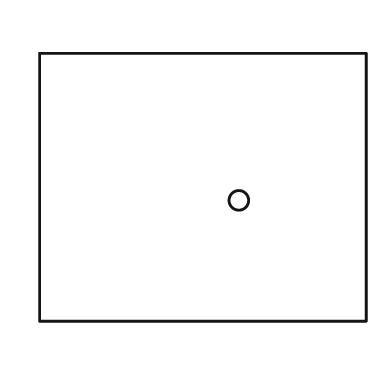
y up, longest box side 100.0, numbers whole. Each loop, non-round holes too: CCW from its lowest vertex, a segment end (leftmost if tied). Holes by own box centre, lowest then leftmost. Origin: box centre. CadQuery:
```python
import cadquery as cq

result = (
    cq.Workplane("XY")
    .moveTo(-50.0, -41.0)
    .lineTo(50.0, -41.0)
    .lineTo(50.0, 41.0)
    .lineTo(-50.0, 41.0)
    .close()
    .moveTo(11.0, -4.0)
    .circle(3.0)
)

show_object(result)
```